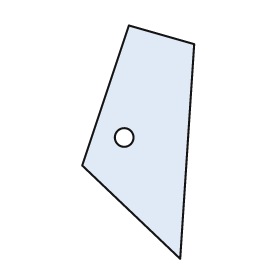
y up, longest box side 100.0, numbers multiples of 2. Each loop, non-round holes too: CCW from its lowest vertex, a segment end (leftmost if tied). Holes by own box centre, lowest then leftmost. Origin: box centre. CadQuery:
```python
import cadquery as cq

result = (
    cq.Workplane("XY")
    .moveTo(18.0, -50.0)
    .lineTo(24.0, 42.0)
    .lineTo(-4.0, 50.0)
    .lineTo(-24.0, -10.0)
    .close()
    .moveTo(-6.0, 2.0)
    .circle(4.0)
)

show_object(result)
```